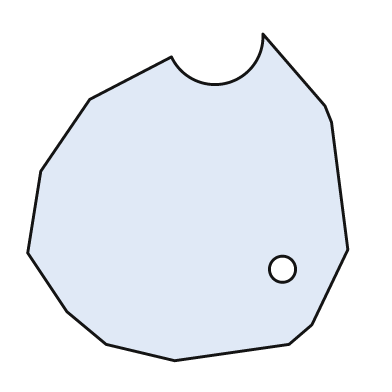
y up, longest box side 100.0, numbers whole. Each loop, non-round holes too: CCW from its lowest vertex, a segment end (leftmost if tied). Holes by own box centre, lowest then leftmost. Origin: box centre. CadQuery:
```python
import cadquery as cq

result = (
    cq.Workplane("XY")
    .moveTo(-4.0, -50.0)
    .lineTo(31.0, -45.0)
    .lineTo(38.0, -39.0)
    .lineTo(49.0, -16.0)
    .lineTo(44.0, 23.0)
    .lineTo(42.0, 28.0)
    .lineTo(23.0, 50.0)
    .threePointArc((12.0, 35.0), (-5.0, 43.0))
    .lineTo(-30.0, 30.0)
    .lineTo(-45.0, 8.0)
    .lineTo(-49.0, -17.0)
    .lineTo(-37.0, -35.0)
    .lineTo(-25.0, -45.0)
    .close()
    .moveTo(29.0, -22.0)
    .circle(4.0)
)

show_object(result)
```